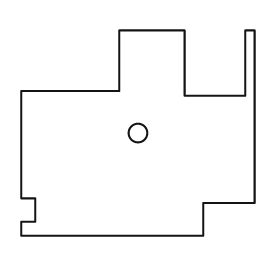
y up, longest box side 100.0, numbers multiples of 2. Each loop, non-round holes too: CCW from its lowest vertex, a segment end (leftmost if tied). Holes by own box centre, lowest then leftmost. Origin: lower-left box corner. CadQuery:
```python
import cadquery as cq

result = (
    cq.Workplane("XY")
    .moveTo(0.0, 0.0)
    .lineTo(78.0, 0.0)
    .lineTo(78.0, 14.0)
    .lineTo(100.0, 14.0)
    .lineTo(100.0, 88.0)
    .lineTo(96.0, 88.0)
    .lineTo(96.0, 60.0)
    .lineTo(70.0, 60.0)
    .lineTo(70.0, 88.0)
    .lineTo(42.0, 88.0)
    .lineTo(42.0, 62.0)
    .lineTo(0.0, 62.0)
    .lineTo(0.0, 16.0)
    .lineTo(6.0, 16.0)
    .lineTo(6.0, 6.0)
    .lineTo(0.0, 6.0)
    .close()
    .moveTo(50.0, 44.0)
    .circle(4.0)
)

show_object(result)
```